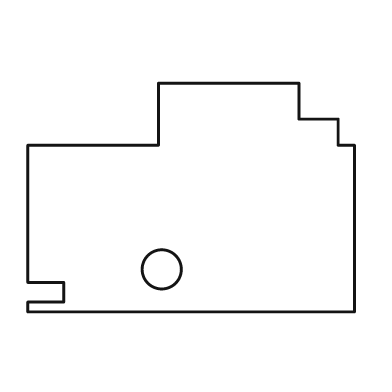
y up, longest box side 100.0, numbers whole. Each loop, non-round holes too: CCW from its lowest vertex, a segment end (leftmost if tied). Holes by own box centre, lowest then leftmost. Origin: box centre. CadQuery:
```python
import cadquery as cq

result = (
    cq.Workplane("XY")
    .moveTo(-50.0, -35.0)
    .lineTo(50.0, -35.0)
    .lineTo(50.0, 16.0)
    .lineTo(45.0, 16.0)
    .lineTo(45.0, 24.0)
    .lineTo(33.0, 24.0)
    .lineTo(33.0, 35.0)
    .lineTo(-10.0, 35.0)
    .lineTo(-10.0, 16.0)
    .lineTo(-50.0, 16.0)
    .lineTo(-50.0, -26.0)
    .lineTo(-39.0, -26.0)
    .lineTo(-39.0, -32.0)
    .lineTo(-50.0, -32.0)
    .close()
    .moveTo(-9.0, -22.0)
    .circle(6.0)
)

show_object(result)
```